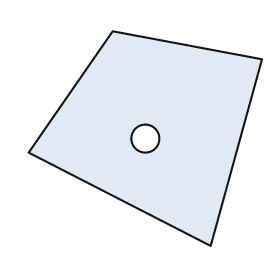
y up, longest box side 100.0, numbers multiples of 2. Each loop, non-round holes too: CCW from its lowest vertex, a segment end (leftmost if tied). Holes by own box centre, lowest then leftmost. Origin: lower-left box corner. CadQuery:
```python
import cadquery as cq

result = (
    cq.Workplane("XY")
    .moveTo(78.0, 0.0)
    .lineTo(100.0, 80.0)
    .lineTo(36.0, 92.0)
    .lineTo(0.0, 40.0)
    .close()
    .moveTo(50.0, 46.0)
    .circle(6.0)
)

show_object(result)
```